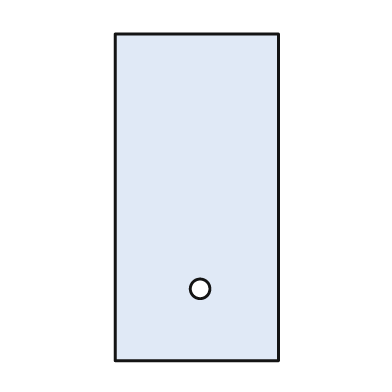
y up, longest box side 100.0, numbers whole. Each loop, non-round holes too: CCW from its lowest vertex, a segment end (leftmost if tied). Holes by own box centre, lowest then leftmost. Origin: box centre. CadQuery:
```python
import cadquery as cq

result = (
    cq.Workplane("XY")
    .moveTo(-25.0, -50.0)
    .lineTo(25.0, -50.0)
    .lineTo(25.0, 50.0)
    .lineTo(-25.0, 50.0)
    .close()
    .moveTo(1.0, -28.0)
    .circle(3.0)
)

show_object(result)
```